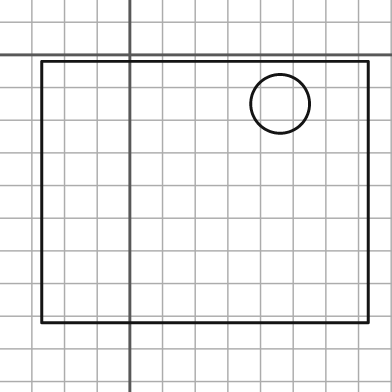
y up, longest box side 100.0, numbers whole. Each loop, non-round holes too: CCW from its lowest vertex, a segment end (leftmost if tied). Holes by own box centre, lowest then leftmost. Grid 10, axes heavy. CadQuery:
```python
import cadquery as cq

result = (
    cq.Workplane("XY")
    .moveTo(-27.0, -82.0)
    .lineTo(73.0, -82.0)
    .lineTo(73.0, -2.0)
    .lineTo(-27.0, -2.0)
    .close()
    .moveTo(46.0, -15.0)
    .circle(9.0)
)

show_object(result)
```